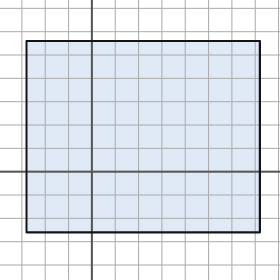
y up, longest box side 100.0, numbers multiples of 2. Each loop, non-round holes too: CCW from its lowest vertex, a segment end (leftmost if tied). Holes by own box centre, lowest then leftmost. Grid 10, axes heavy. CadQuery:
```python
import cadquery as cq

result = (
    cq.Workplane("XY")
    .moveTo(-28.0, -26.0)
    .lineTo(72.0, -26.0)
    .lineTo(72.0, 56.0)
    .lineTo(-28.0, 56.0)
    .close()
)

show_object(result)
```